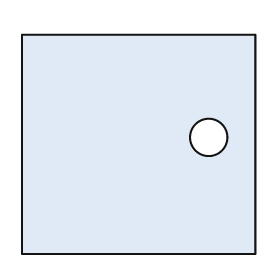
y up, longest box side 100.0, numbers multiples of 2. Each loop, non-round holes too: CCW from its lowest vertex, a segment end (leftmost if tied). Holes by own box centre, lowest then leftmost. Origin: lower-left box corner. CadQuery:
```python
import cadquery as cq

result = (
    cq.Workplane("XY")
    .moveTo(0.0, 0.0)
    .lineTo(100.0, 0.0)
    .lineTo(100.0, 94.0)
    .lineTo(0.0, 94.0)
    .close()
    .moveTo(80.0, 50.0)
    .circle(8.0)
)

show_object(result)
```